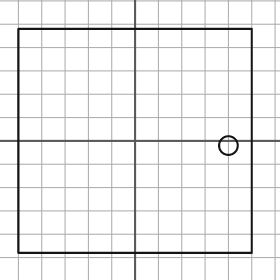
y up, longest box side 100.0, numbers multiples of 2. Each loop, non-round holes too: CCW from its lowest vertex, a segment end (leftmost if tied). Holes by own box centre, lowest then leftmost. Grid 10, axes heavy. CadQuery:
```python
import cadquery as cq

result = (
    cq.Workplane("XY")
    .moveTo(-50.0, -48.0)
    .lineTo(50.0, -48.0)
    .lineTo(50.0, 48.0)
    .lineTo(-50.0, 48.0)
    .close()
    .moveTo(40.0, -2.0)
    .circle(4.0)
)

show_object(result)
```